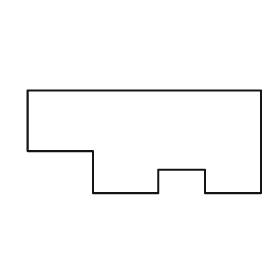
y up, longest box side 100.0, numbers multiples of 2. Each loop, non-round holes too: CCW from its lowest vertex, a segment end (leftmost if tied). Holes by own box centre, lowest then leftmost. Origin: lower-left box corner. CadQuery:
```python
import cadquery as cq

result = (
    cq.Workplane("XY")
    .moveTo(28.0, 0.0)
    .lineTo(56.0, 0.0)
    .lineTo(56.0, 10.0)
    .lineTo(76.0, 10.0)
    .lineTo(76.0, 0.0)
    .lineTo(100.0, 0.0)
    .lineTo(100.0, 44.0)
    .lineTo(0.0, 44.0)
    .lineTo(0.0, 18.0)
    .lineTo(28.0, 18.0)
    .close()
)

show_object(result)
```